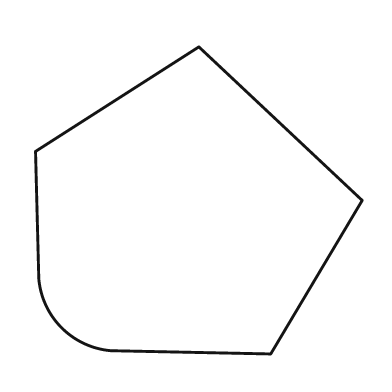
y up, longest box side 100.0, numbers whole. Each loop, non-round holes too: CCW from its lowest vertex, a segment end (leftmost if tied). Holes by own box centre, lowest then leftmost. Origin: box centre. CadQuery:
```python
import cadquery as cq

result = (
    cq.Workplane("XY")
    .moveTo(22.0, -47.0)
    .lineTo(50.0, 0.0)
    .lineTo(0.0, 47.0)
    .lineTo(-50.0, 15.0)
    .lineTo(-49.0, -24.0)
    .threePointArc((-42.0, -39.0), (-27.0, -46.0))
    .close()
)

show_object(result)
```